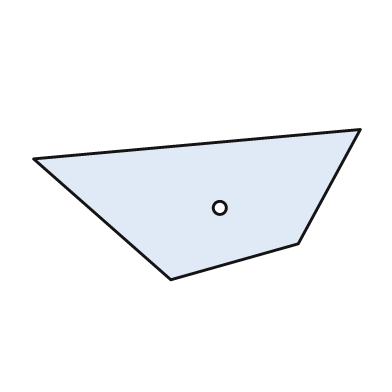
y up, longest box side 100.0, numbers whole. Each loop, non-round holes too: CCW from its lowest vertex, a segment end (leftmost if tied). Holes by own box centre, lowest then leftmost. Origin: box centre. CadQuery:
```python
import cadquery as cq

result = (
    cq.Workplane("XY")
    .moveTo(-8.0, -23.0)
    .lineTo(31.0, -12.0)
    .lineTo(50.0, 23.0)
    .lineTo(-50.0, 14.0)
    .close()
    .moveTo(7.0, -1.0)
    .circle(2.0)
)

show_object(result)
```